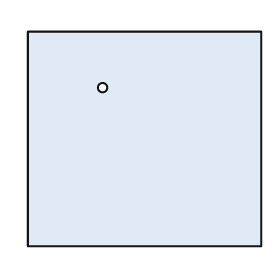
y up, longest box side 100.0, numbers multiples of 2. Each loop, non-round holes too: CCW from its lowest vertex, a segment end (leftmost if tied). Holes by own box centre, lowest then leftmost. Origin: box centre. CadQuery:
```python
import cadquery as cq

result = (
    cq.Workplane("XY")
    .moveTo(-50.0, -46.0)
    .lineTo(50.0, -46.0)
    .lineTo(50.0, 46.0)
    .lineTo(-50.0, 46.0)
    .close()
    .moveTo(-18.0, 22.0)
    .circle(2.0)
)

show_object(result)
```